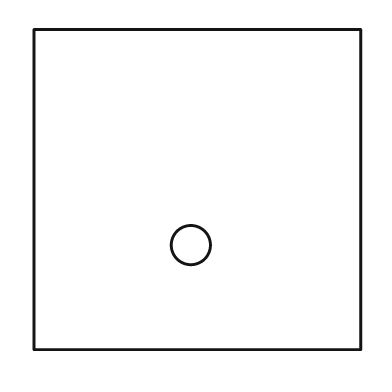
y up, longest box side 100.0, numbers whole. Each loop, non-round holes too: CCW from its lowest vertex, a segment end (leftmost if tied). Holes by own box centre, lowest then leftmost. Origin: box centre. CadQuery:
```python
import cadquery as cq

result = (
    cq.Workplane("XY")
    .moveTo(-50.0, -49.0)
    .lineTo(50.0, -49.0)
    .lineTo(50.0, 49.0)
    .lineTo(-50.0, 49.0)
    .close()
    .moveTo(-2.0, -17.0)
    .circle(6.0)
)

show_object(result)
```